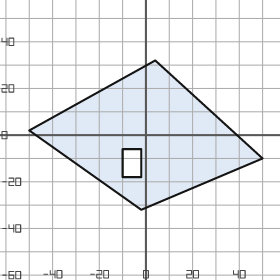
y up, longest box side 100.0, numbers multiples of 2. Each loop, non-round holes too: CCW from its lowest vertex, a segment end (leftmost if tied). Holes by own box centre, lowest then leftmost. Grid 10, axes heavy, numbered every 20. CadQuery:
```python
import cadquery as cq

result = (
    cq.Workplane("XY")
    .moveTo(-2.0, -32.0)
    .lineTo(50.0, -10.0)
    .lineTo(4.0, 32.0)
    .lineTo(-50.0, 2.0)
    .close()
    .moveTo(-10.0, -18.0)
    .lineTo(-2.0, -18.0)
    .lineTo(-2.0, -6.0)
    .lineTo(-10.0, -6.0)
    .close()
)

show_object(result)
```